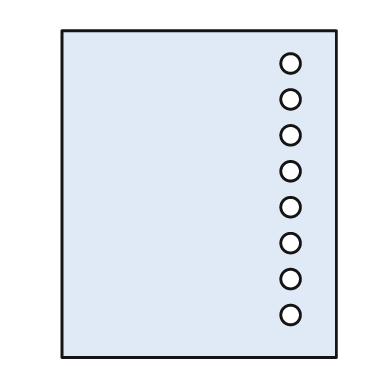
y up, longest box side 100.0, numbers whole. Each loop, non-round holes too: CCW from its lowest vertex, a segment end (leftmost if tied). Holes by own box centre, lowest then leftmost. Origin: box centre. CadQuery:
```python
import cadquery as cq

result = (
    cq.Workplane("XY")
    .moveTo(-42.0, -50.0)
    .lineTo(42.0, -50.0)
    .lineTo(42.0, 50.0)
    .lineTo(-42.0, 50.0)
    .close()
    .moveTo(28.0, -37.0)
    .circle(3.0)
    .moveTo(28.0, -26.0)
    .circle(3.0)
    .moveTo(28.0, -15.0)
    .circle(3.0)
    .moveTo(28.0, -4.0)
    .circle(3.0)
    .moveTo(28.0, 7.0)
    .circle(3.0)
    .moveTo(28.0, 18.0)
    .circle(3.0)
    .moveTo(28.0, 29.0)
    .circle(3.0)
    .moveTo(28.0, 40.0)
    .circle(3.0)
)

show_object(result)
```